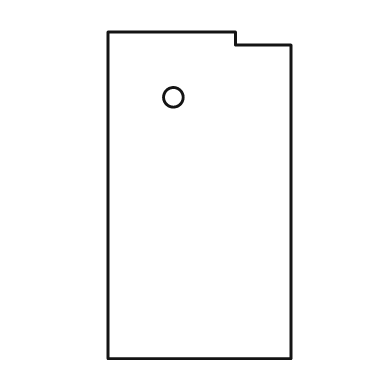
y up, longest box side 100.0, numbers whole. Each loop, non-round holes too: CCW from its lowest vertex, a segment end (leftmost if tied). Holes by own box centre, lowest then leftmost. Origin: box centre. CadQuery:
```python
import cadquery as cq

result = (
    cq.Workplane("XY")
    .moveTo(-28.0, -50.0)
    .lineTo(28.0, -50.0)
    .lineTo(28.0, 46.0)
    .lineTo(11.0, 46.0)
    .lineTo(11.0, 50.0)
    .lineTo(-28.0, 50.0)
    .close()
    .moveTo(-8.0, 30.0)
    .circle(3.0)
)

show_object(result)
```